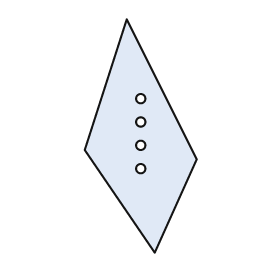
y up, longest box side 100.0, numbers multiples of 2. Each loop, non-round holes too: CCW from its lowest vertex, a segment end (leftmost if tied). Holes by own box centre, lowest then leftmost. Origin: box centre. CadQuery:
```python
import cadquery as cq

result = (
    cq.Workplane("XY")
    .moveTo(6.0, -50.0)
    .lineTo(24.0, -10.0)
    .lineTo(-6.0, 50.0)
    .lineTo(-24.0, -6.0)
    .close()
    .moveTo(0.0, -14.0)
    .circle(2.0)
    .moveTo(0.0, -4.0)
    .circle(2.0)
    .moveTo(0.0, 6.0)
    .circle(2.0)
    .moveTo(0.0, 16.0)
    .circle(2.0)
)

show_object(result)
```